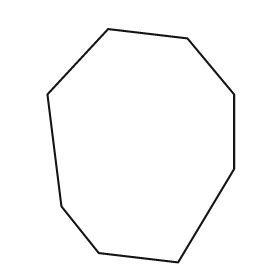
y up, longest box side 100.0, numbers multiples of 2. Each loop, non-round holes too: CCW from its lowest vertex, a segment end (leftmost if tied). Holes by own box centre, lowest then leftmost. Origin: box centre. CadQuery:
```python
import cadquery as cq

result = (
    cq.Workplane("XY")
    .moveTo(16.0, -50.0)
    .lineTo(40.0, -10.0)
    .lineTo(40.0, 22.0)
    .lineTo(20.0, 46.0)
    .lineTo(-14.0, 50.0)
    .lineTo(-40.0, 22.0)
    .lineTo(-34.0, -26.0)
    .lineTo(-18.0, -46.0)
    .close()
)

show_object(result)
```